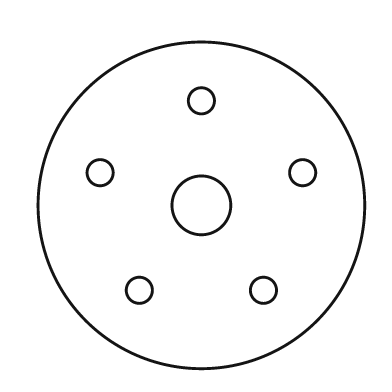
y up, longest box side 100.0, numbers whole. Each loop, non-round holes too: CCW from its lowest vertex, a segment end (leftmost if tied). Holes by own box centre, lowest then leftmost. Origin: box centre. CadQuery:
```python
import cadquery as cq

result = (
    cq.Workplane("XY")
    .moveTo(0.0, 0.0)
    .circle(50.0)
    .moveTo(-19.0, -26.0)
    .circle(4.0)
    .moveTo(19.0, -26.0)
    .circle(4.0)
    .moveTo(0.0, 0.0)
    .circle(9.0)
    .moveTo(-31.0, 10.0)
    .circle(4.0)
    .moveTo(31.0, 10.0)
    .circle(4.0)
    .moveTo(0.0, 32.0)
    .circle(4.0)
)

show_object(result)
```